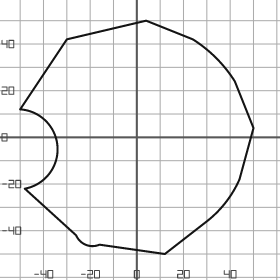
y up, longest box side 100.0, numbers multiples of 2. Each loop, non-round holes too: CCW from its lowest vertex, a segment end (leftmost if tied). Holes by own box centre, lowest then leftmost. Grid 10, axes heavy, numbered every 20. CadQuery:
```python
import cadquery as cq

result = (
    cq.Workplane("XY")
    .moveTo(12.0, -50.0)
    .lineTo(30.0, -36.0)
    .threePointArc((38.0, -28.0), (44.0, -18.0))
    .lineTo(50.0, 4.0)
    .lineTo(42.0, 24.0)
    .threePointArc((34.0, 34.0), (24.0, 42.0))
    .lineTo(4.0, 50.0)
    .lineTo(-30.0, 42.0)
    .lineTo(-50.0, 12.0)
    .threePointArc((-34.0, -4.0), (-48.0, -22.0))
    .lineTo(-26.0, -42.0)
    .threePointArc((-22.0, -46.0), (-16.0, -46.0))
    .close()
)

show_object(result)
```